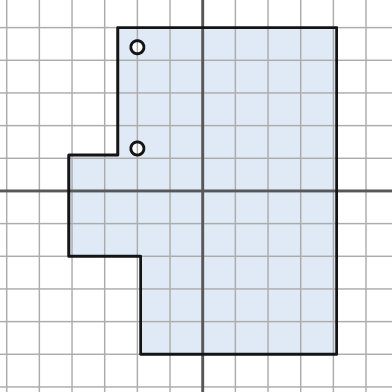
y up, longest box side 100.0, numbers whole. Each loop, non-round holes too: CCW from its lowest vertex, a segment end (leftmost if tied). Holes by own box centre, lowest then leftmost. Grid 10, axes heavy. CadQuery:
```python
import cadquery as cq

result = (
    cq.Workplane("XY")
    .moveTo(-19.0, -50.0)
    .lineTo(41.0, -50.0)
    .lineTo(41.0, 50.0)
    .lineTo(-26.0, 50.0)
    .lineTo(-26.0, 11.0)
    .lineTo(-41.0, 11.0)
    .lineTo(-41.0, -20.0)
    .lineTo(-19.0, -20.0)
    .close()
    .moveTo(-20.0, 13.0)
    .circle(2.0)
    .moveTo(-20.0, 44.0)
    .circle(2.0)
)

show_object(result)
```